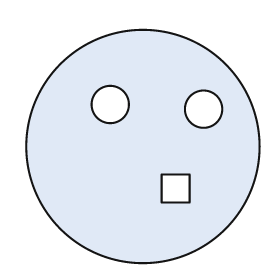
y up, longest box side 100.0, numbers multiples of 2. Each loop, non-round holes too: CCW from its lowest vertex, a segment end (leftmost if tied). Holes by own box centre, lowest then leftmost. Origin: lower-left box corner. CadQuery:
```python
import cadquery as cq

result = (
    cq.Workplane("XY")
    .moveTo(50.0, 50.0)
    .circle(50.0)
    .moveTo(58.0, 26.0)
    .lineTo(70.0, 26.0)
    .lineTo(70.0, 38.0)
    .lineTo(58.0, 38.0)
    .close()
    .moveTo(76.0, 66.0)
    .circle(8.0)
    .moveTo(36.0, 68.0)
    .circle(8.0)
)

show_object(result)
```